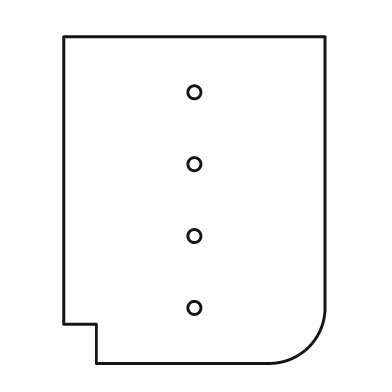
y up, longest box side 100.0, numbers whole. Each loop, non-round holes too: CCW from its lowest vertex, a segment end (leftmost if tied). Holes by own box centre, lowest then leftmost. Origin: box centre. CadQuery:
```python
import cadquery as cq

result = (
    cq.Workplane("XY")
    .moveTo(-30.0, -50.0)
    .lineTo(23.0, -50.0)
    .threePointArc((35.0, -45.0), (40.0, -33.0))
    .lineTo(40.0, 50.0)
    .lineTo(-40.0, 50.0)
    .lineTo(-40.0, -38.0)
    .lineTo(-30.0, -38.0)
    .close()
    .moveTo(0.0, -33.0)
    .circle(2.0)
    .moveTo(0.0, -11.0)
    .circle(2.0)
    .moveTo(0.0, 11.0)
    .circle(2.0)
    .moveTo(0.0, 33.0)
    .circle(2.0)
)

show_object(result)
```